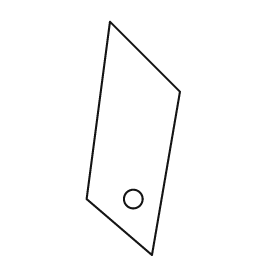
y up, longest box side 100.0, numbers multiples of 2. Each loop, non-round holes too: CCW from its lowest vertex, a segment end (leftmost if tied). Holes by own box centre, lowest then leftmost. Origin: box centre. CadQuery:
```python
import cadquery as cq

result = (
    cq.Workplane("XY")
    .moveTo(8.0, -50.0)
    .lineTo(20.0, 20.0)
    .lineTo(-10.0, 50.0)
    .lineTo(-20.0, -26.0)
    .close()
    .moveTo(0.0, -26.0)
    .circle(4.0)
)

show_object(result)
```